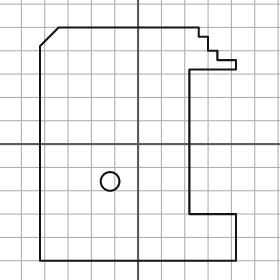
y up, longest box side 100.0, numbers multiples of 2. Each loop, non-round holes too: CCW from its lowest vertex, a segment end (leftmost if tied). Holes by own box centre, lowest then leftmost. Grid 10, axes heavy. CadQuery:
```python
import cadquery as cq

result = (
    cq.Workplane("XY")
    .moveTo(-42.0, -50.0)
    .lineTo(42.0, -50.0)
    .lineTo(42.0, -30.0)
    .lineTo(22.0, -30.0)
    .lineTo(22.0, 32.0)
    .lineTo(42.0, 32.0)
    .lineTo(42.0, 36.0)
    .lineTo(34.0, 36.0)
    .lineTo(34.0, 40.0)
    .lineTo(30.0, 40.0)
    .lineTo(30.0, 46.0)
    .lineTo(26.0, 46.0)
    .lineTo(26.0, 50.0)
    .lineTo(-34.0, 50.0)
    .lineTo(-42.0, 42.0)
    .close()
    .moveTo(-12.0, -16.0)
    .circle(4.0)
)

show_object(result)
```